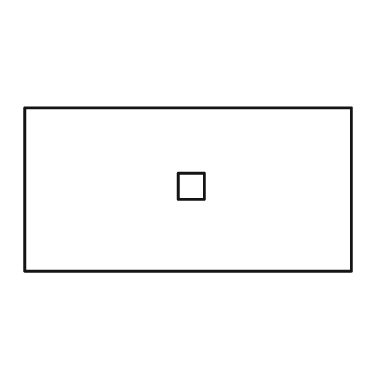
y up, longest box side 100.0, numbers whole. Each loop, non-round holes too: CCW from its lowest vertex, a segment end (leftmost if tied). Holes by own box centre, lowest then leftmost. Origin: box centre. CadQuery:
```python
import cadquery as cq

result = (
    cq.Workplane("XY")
    .moveTo(-50.0, -25.0)
    .lineTo(50.0, -25.0)
    .lineTo(50.0, 25.0)
    .lineTo(-50.0, 25.0)
    .close()
    .moveTo(-3.0, -3.0)
    .lineTo(5.0, -3.0)
    .lineTo(5.0, 5.0)
    .lineTo(-3.0, 5.0)
    .close()
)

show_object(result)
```